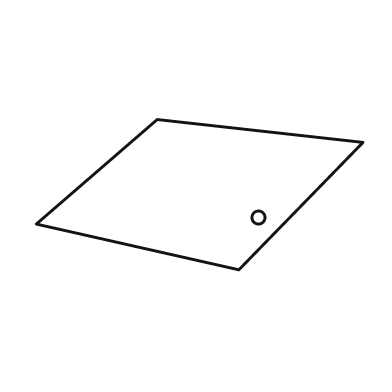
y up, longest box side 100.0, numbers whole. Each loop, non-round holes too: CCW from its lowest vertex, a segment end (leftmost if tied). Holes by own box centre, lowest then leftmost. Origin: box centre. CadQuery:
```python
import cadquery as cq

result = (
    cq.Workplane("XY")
    .moveTo(12.0, -23.0)
    .lineTo(50.0, 16.0)
    .lineTo(-13.0, 23.0)
    .lineTo(-50.0, -9.0)
    .close()
    .moveTo(18.0, -7.0)
    .circle(2.0)
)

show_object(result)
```